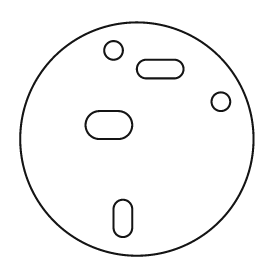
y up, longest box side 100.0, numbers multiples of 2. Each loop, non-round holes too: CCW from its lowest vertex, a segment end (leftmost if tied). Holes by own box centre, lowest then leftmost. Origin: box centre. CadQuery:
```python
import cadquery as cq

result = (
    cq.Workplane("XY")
    .moveTo(0.0, 0.0)
    .circle(50.0)
    .moveTo(-10.0, -38.0)
    .threePointArc((-6.0, -42.0), (-2.0, -38.0))
    .lineTo(-2.0, -30.0)
    .threePointArc((-6.0, -26.0), (-10.0, -30.0))
    .close()
    .moveTo(-16.0, 0.0)
    .lineTo(-8.0, 0.0)
    .threePointArc((-2.0, 6.0), (-8.0, 12.0))
    .lineTo(-16.0, 12.0)
    .threePointArc((-22.0, 6.0), (-16.0, 0.0))
    .close()
    .moveTo(36.0, 16.0)
    .circle(4.0)
    .moveTo(4.0, 26.0)
    .lineTo(16.0, 26.0)
    .threePointArc((20.0, 30.0), (16.0, 34.0))
    .lineTo(4.0, 34.0)
    .threePointArc((0.0, 30.0), (4.0, 26.0))
    .close()
    .moveTo(-10.0, 38.0)
    .circle(4.0)
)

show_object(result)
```